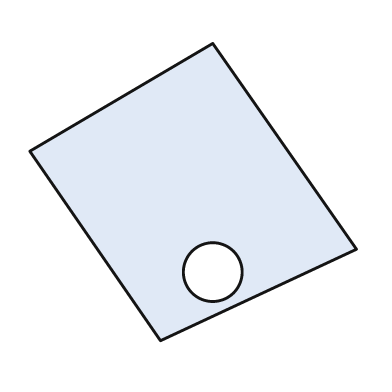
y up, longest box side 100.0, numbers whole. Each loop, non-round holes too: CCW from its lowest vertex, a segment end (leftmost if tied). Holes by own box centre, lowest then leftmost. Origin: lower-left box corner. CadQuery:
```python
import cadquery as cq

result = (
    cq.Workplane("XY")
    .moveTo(40.0, 0.0)
    .lineTo(100.0, 28.0)
    .lineTo(56.0, 91.0)
    .lineTo(0.0, 58.0)
    .close()
    .moveTo(56.0, 21.0)
    .circle(9.0)
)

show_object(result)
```